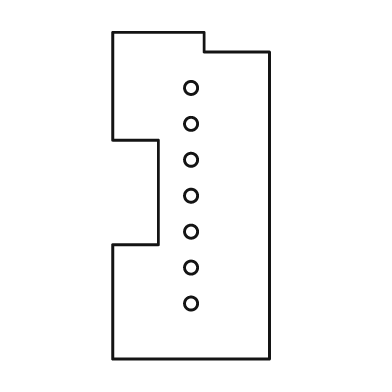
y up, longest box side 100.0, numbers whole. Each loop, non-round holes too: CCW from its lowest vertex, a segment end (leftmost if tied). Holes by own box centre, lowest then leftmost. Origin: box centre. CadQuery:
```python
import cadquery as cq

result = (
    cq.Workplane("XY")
    .moveTo(-24.0, -50.0)
    .lineTo(24.0, -50.0)
    .lineTo(24.0, 44.0)
    .lineTo(4.0, 44.0)
    .lineTo(4.0, 50.0)
    .lineTo(-24.0, 50.0)
    .lineTo(-24.0, 17.0)
    .lineTo(-10.0, 17.0)
    .lineTo(-10.0, -15.0)
    .lineTo(-24.0, -15.0)
    .close()
    .moveTo(0.0, -33.0)
    .circle(2.0)
    .moveTo(0.0, -22.0)
    .circle(2.0)
    .moveTo(0.0, -11.0)
    .circle(2.0)
    .moveTo(0.0, 0.0)
    .circle(2.0)
    .moveTo(0.0, 11.0)
    .circle(2.0)
    .moveTo(0.0, 22.0)
    .circle(2.0)
    .moveTo(0.0, 33.0)
    .circle(2.0)
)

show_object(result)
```